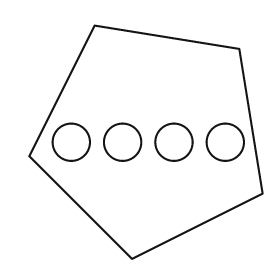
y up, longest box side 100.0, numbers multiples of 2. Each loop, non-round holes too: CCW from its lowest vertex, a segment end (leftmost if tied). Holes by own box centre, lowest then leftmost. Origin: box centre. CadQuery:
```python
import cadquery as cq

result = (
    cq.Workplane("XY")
    .moveTo(-6.0, -50.0)
    .lineTo(50.0, -22.0)
    .lineTo(40.0, 40.0)
    .lineTo(-22.0, 50.0)
    .lineTo(-50.0, -6.0)
    .close()
    .moveTo(-32.0, 0.0)
    .circle(8.0)
    .moveTo(-10.0, 0.0)
    .circle(8.0)
    .moveTo(12.0, 0.0)
    .circle(8.0)
    .moveTo(34.0, 0.0)
    .circle(8.0)
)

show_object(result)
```